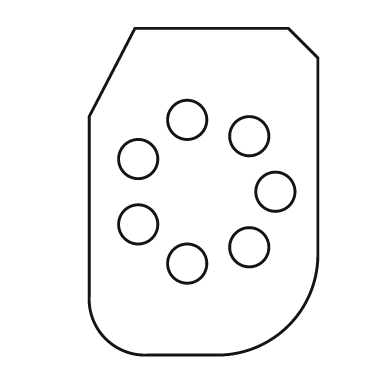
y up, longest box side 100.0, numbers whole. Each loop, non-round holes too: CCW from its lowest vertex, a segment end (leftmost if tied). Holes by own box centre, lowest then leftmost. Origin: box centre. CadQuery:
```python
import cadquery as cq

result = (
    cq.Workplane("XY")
    .moveTo(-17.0, -50.0)
    .lineTo(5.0, -50.0)
    .threePointArc((26.0, -41.0), (35.0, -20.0))
    .lineTo(35.0, 41.0)
    .lineTo(26.0, 50.0)
    .lineTo(-21.0, 50.0)
    .lineTo(-35.0, 23.0)
    .lineTo(-35.0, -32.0)
    .threePointArc((-30.0, -45.0), (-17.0, -50.0))
    .close()
    .moveTo(-5.0, -22.0)
    .circle(6.0)
    .moveTo(14.0, -17.0)
    .circle(6.0)
    .moveTo(-20.0, -10.0)
    .circle(6.0)
    .moveTo(22.0, 0.0)
    .circle(6.0)
    .moveTo(-20.0, 10.0)
    .circle(6.0)
    .moveTo(14.0, 17.0)
    .circle(6.0)
    .moveTo(-5.0, 22.0)
    .circle(6.0)
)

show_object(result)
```